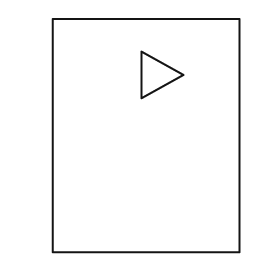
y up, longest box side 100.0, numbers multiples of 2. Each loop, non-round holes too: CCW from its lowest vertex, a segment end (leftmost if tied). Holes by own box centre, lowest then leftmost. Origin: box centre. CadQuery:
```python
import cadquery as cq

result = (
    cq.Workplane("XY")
    .moveTo(-40.0, -50.0)
    .lineTo(40.0, -50.0)
    .lineTo(40.0, 50.0)
    .lineTo(-40.0, 50.0)
    .close()
    .moveTo(-2.0, 16.0)
    .lineTo(16.0, 26.0)
    .lineTo(-2.0, 36.0)
    .close()
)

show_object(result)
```